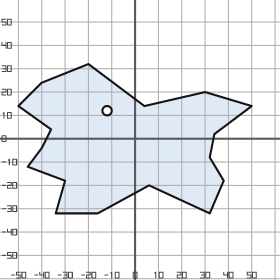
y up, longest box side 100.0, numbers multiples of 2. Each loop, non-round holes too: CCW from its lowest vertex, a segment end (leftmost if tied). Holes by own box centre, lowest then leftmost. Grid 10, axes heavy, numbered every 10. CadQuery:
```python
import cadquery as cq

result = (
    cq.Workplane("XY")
    .moveTo(-34.0, -32.0)
    .lineTo(-16.0, -32.0)
    .lineTo(6.0, -20.0)
    .lineTo(32.0, -32.0)
    .lineTo(38.0, -18.0)
    .lineTo(32.0, -8.0)
    .lineTo(34.0, 2.0)
    .lineTo(50.0, 14.0)
    .lineTo(30.0, 20.0)
    .lineTo(4.0, 14.0)
    .lineTo(-20.0, 32.0)
    .lineTo(-40.0, 24.0)
    .lineTo(-50.0, 14.0)
    .lineTo(-36.0, 4.0)
    .lineTo(-40.0, -4.0)
    .lineTo(-46.0, -12.0)
    .lineTo(-30.0, -18.0)
    .close()
    .moveTo(-12.0, 12.0)
    .circle(2.0)
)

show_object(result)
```